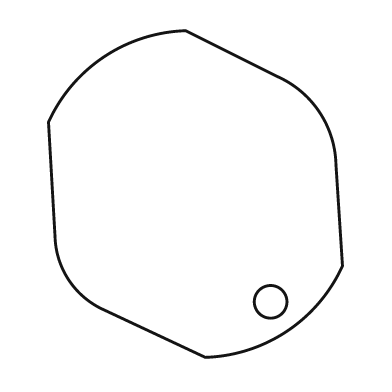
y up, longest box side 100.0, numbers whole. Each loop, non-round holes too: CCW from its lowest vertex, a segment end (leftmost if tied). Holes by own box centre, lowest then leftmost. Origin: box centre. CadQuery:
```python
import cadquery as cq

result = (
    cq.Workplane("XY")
    .moveTo(3.0, -50.0)
    .threePointArc((28.0, -42.0), (45.0, -22.0))
    .lineTo(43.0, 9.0)
    .threePointArc((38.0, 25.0), (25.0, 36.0))
    .lineTo(-3.0, 50.0)
    .threePointArc((-28.0, 42.0), (-45.0, 22.0))
    .lineTo(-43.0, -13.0)
    .threePointArc((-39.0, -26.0), (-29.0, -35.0))
    .close()
    .moveTo(23.0, -33.0)
    .circle(5.0)
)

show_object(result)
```